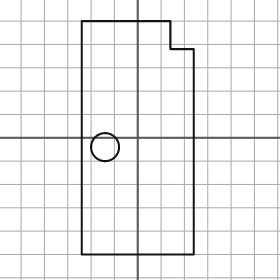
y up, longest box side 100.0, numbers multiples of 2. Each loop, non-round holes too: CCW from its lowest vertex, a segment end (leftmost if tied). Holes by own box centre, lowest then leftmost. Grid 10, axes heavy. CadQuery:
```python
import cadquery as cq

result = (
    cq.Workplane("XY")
    .moveTo(-24.0, -50.0)
    .lineTo(24.0, -50.0)
    .lineTo(24.0, 38.0)
    .lineTo(14.0, 38.0)
    .lineTo(14.0, 50.0)
    .lineTo(-24.0, 50.0)
    .close()
    .moveTo(-14.0, -4.0)
    .circle(6.0)
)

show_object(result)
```